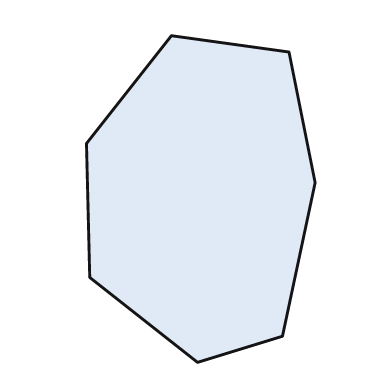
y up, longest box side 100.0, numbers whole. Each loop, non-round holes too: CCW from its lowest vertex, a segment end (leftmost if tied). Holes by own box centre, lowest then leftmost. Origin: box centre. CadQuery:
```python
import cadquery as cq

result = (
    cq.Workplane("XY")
    .moveTo(-1.0, -50.0)
    .lineTo(25.0, -42.0)
    .lineTo(35.0, 5.0)
    .lineTo(27.0, 45.0)
    .lineTo(-9.0, 50.0)
    .lineTo(-35.0, 17.0)
    .lineTo(-34.0, -24.0)
    .close()
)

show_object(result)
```